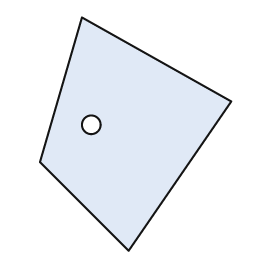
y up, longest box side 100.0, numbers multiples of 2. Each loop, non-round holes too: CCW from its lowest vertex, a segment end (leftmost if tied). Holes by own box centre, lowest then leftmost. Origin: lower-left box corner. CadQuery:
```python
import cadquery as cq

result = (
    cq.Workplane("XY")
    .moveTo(38.0, 0.0)
    .lineTo(82.0, 64.0)
    .lineTo(18.0, 100.0)
    .lineTo(0.0, 38.0)
    .close()
    .moveTo(22.0, 54.0)
    .circle(4.0)
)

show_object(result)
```